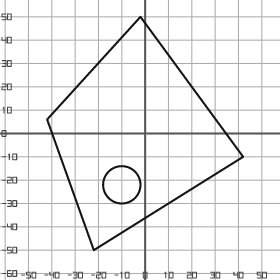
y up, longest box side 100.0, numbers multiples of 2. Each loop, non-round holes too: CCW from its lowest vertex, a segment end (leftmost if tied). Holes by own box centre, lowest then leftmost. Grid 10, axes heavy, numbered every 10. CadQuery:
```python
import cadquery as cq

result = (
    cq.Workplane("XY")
    .moveTo(-22.0, -50.0)
    .lineTo(42.0, -10.0)
    .lineTo(-2.0, 50.0)
    .lineTo(-42.0, 6.0)
    .close()
    .moveTo(-10.0, -22.0)
    .circle(8.0)
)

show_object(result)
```